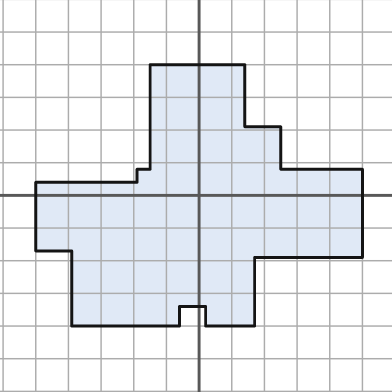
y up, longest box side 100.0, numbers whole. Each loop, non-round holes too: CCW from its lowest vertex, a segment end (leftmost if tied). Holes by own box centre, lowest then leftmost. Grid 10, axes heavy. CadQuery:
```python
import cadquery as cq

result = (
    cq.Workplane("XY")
    .moveTo(-39.0, -40.0)
    .lineTo(-6.0, -40.0)
    .lineTo(-6.0, -34.0)
    .lineTo(2.0, -34.0)
    .lineTo(2.0, -40.0)
    .lineTo(17.0, -40.0)
    .lineTo(17.0, -19.0)
    .lineTo(50.0, -19.0)
    .lineTo(50.0, 8.0)
    .lineTo(25.0, 8.0)
    .lineTo(25.0, 21.0)
    .lineTo(14.0, 21.0)
    .lineTo(14.0, 40.0)
    .lineTo(-15.0, 40.0)
    .lineTo(-15.0, 8.0)
    .lineTo(-19.0, 8.0)
    .lineTo(-19.0, 4.0)
    .lineTo(-50.0, 4.0)
    .lineTo(-50.0, -17.0)
    .lineTo(-39.0, -17.0)
    .close()
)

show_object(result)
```